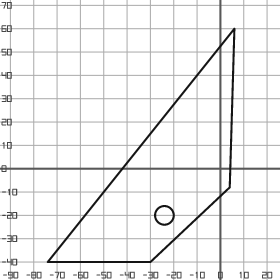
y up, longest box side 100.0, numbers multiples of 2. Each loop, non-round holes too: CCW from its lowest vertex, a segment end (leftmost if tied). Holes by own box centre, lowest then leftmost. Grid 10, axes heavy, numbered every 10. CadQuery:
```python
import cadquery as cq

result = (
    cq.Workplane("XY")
    .moveTo(-74.0, -40.0)
    .lineTo(-30.0, -40.0)
    .lineTo(4.0, -8.0)
    .lineTo(6.0, 60.0)
    .close()
    .moveTo(-24.0, -20.0)
    .circle(4.0)
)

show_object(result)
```